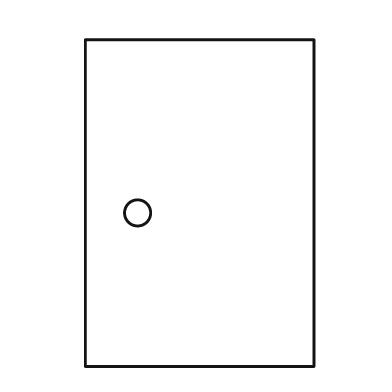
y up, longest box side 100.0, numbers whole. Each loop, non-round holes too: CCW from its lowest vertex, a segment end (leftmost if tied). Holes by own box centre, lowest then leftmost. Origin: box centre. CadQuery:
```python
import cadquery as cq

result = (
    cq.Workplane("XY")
    .moveTo(-35.0, -50.0)
    .lineTo(35.0, -50.0)
    .lineTo(35.0, 50.0)
    .lineTo(-35.0, 50.0)
    .close()
    .moveTo(-19.0, -3.0)
    .circle(4.0)
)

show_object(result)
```